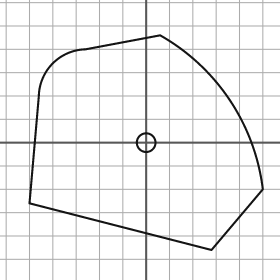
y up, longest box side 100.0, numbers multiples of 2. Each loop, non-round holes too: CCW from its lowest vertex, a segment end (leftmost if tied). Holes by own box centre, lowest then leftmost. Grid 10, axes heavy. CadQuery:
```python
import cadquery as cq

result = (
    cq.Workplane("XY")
    .moveTo(28.0, -46.0)
    .lineTo(50.0, -20.0)
    .threePointArc((36.0, 18.0), (6.0, 46.0))
    .lineTo(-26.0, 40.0)
    .threePointArc((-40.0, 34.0), (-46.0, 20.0))
    .lineTo(-50.0, -26.0)
    .close()
    .moveTo(0.0, 0.0)
    .circle(4.0)
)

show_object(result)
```